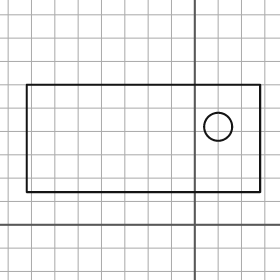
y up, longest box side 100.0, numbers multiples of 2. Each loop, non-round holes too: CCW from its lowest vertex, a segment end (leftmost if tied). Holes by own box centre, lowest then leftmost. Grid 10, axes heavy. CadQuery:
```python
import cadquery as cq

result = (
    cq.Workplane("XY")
    .moveTo(-72.0, 14.0)
    .lineTo(28.0, 14.0)
    .lineTo(28.0, 60.0)
    .lineTo(-72.0, 60.0)
    .close()
    .moveTo(10.0, 42.0)
    .circle(6.0)
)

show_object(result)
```